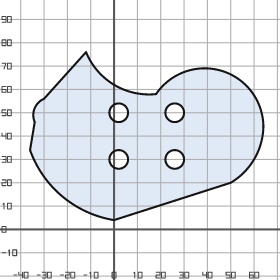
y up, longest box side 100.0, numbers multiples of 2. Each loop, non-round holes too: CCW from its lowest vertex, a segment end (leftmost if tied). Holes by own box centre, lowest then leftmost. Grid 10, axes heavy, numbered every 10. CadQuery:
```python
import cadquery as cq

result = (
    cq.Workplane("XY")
    .moveTo(0.0, 4.0)
    .lineTo(50.0, 20.0)
    .threePointArc((60.0, 30.0), (64.0, 44.0))
    .threePointArc((46.0, 68.0), (18.0, 58.0))
    .threePointArc((0.0, 62.0), (-12.0, 76.0))
    .lineTo(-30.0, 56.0)
    .threePointArc((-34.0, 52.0), (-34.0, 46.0))
    .lineTo(-36.0, 34.0)
    .threePointArc((-22.0, 14.0), (0.0, 4.0))
    .close()
    .moveTo(2.0, 30.0)
    .circle(4.0)
    .moveTo(26.0, 30.0)
    .circle(4.0)
    .moveTo(2.0, 50.0)
    .circle(4.0)
    .moveTo(26.0, 50.0)
    .circle(4.0)
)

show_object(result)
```